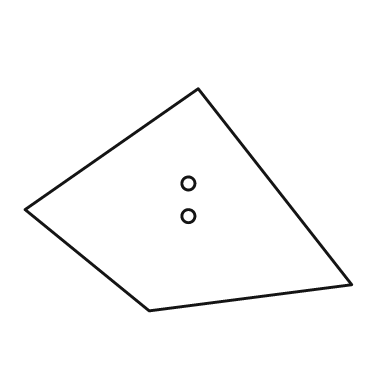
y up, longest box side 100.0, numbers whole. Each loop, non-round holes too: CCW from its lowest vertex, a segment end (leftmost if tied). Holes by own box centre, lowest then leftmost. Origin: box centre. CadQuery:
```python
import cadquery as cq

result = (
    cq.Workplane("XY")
    .moveTo(-12.0, -34.0)
    .lineTo(50.0, -26.0)
    .lineTo(3.0, 34.0)
    .lineTo(-50.0, -3.0)
    .close()
    .moveTo(0.0, -5.0)
    .circle(2.0)
    .moveTo(0.0, 5.0)
    .circle(2.0)
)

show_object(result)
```